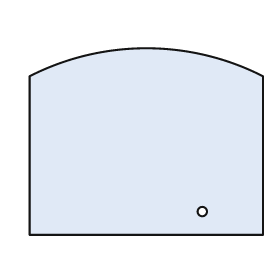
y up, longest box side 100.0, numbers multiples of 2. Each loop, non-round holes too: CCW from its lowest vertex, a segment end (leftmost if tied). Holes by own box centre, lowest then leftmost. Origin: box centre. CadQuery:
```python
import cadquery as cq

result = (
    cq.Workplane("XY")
    .moveTo(-50.0, -40.0)
    .lineTo(50.0, -40.0)
    .lineTo(50.0, 28.0)
    .threePointArc((0.0, 40.0), (-50.0, 28.0))
    .close()
    .moveTo(24.0, -30.0)
    .circle(2.0)
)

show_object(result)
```